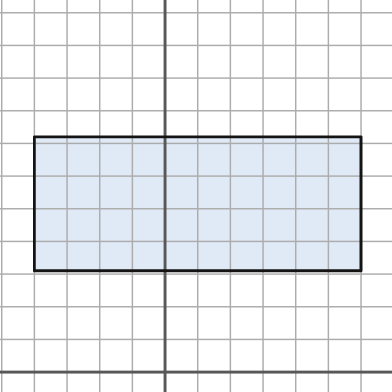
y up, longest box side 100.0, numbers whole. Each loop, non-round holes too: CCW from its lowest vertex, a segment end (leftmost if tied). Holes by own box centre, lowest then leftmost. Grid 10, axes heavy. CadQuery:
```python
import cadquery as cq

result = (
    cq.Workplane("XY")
    .moveTo(-40.0, 31.0)
    .lineTo(60.0, 31.0)
    .lineTo(60.0, 72.0)
    .lineTo(-40.0, 72.0)
    .close()
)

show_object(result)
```